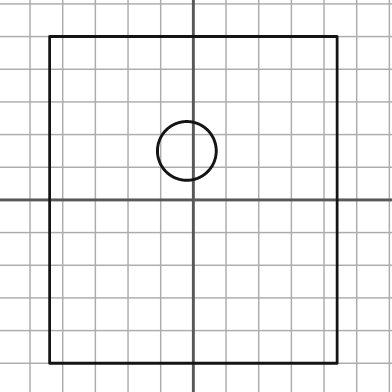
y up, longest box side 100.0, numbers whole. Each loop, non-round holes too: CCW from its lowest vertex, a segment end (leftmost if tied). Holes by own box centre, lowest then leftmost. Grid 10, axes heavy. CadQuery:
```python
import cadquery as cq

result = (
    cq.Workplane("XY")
    .moveTo(-44.0, -50.0)
    .lineTo(44.0, -50.0)
    .lineTo(44.0, 50.0)
    .lineTo(-44.0, 50.0)
    .close()
    .moveTo(-2.0, 15.0)
    .circle(9.0)
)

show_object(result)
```